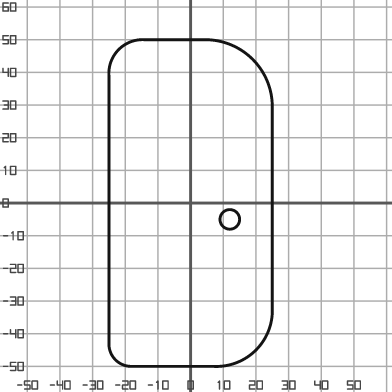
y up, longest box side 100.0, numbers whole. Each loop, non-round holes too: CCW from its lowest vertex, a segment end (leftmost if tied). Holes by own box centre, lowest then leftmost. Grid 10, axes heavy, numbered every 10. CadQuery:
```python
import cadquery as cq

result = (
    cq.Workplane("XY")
    .moveTo(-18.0, -50.0)
    .lineTo(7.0, -50.0)
    .threePointArc((20.0, -45.0), (25.0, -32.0))
    .lineTo(25.0, 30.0)
    .threePointArc((19.0, 44.0), (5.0, 50.0))
    .lineTo(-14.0, 50.0)
    .threePointArc((-22.0, 47.0), (-25.0, 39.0))
    .lineTo(-25.0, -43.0)
    .threePointArc((-23.0, -48.0), (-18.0, -50.0))
    .close()
    .moveTo(12.0, -5.0)
    .circle(3.0)
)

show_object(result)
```